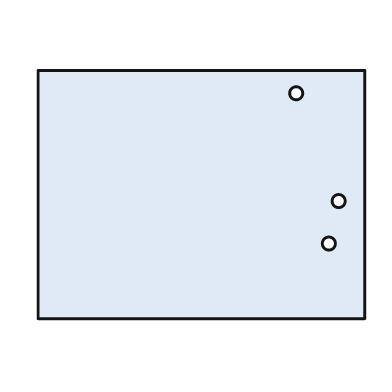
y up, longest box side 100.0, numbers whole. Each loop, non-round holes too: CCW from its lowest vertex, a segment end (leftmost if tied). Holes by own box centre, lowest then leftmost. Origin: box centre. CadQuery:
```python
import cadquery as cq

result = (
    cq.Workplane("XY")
    .moveTo(-50.0, -38.0)
    .lineTo(50.0, -38.0)
    .lineTo(50.0, 38.0)
    .lineTo(-50.0, 38.0)
    .close()
    .moveTo(39.0, -15.0)
    .circle(2.0)
    .moveTo(42.0, -2.0)
    .circle(2.0)
    .moveTo(29.0, 31.0)
    .circle(2.0)
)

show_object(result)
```